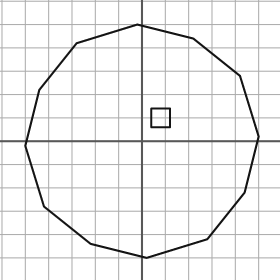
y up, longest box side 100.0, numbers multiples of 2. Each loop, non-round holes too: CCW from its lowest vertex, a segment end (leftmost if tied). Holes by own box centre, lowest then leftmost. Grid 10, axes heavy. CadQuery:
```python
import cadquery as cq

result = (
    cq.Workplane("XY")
    .moveTo(2.0, -50.0)
    .lineTo(28.0, -42.0)
    .lineTo(44.0, -22.0)
    .lineTo(50.0, 2.0)
    .lineTo(42.0, 28.0)
    .lineTo(22.0, 44.0)
    .lineTo(-2.0, 50.0)
    .lineTo(-28.0, 42.0)
    .lineTo(-44.0, 22.0)
    .lineTo(-50.0, -2.0)
    .lineTo(-42.0, -28.0)
    .lineTo(-22.0, -44.0)
    .close()
    .moveTo(4.0, 6.0)
    .lineTo(12.0, 6.0)
    .lineTo(12.0, 14.0)
    .lineTo(4.0, 14.0)
    .close()
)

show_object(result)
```